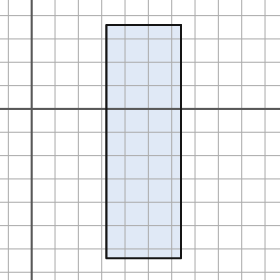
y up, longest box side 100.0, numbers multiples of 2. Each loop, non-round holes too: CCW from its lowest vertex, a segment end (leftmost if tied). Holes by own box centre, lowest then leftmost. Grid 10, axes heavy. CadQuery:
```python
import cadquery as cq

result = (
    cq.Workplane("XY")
    .moveTo(32.0, -64.0)
    .lineTo(64.0, -64.0)
    .lineTo(64.0, 36.0)
    .lineTo(32.0, 36.0)
    .close()
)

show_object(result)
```